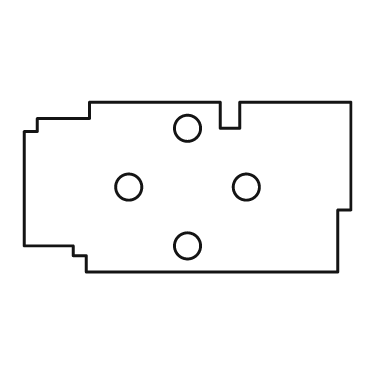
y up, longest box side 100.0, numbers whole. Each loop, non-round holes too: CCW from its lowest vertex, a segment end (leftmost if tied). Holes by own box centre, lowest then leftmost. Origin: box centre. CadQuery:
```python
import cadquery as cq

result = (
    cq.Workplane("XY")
    .moveTo(-31.0, -26.0)
    .lineTo(46.0, -26.0)
    .lineTo(46.0, -7.0)
    .lineTo(50.0, -7.0)
    .lineTo(50.0, 26.0)
    .lineTo(16.0, 26.0)
    .lineTo(16.0, 18.0)
    .lineTo(10.0, 18.0)
    .lineTo(10.0, 26.0)
    .lineTo(-30.0, 26.0)
    .lineTo(-30.0, 21.0)
    .lineTo(-46.0, 21.0)
    .lineTo(-46.0, 17.0)
    .lineTo(-50.0, 17.0)
    .lineTo(-50.0, -18.0)
    .lineTo(-35.0, -18.0)
    .lineTo(-35.0, -21.0)
    .lineTo(-31.0, -21.0)
    .close()
    .moveTo(0.0, -18.0)
    .circle(4.0)
    .moveTo(-18.0, 0.0)
    .circle(4.0)
    .moveTo(18.0, 0.0)
    .circle(4.0)
    .moveTo(0.0, 18.0)
    .circle(4.0)
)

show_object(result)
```